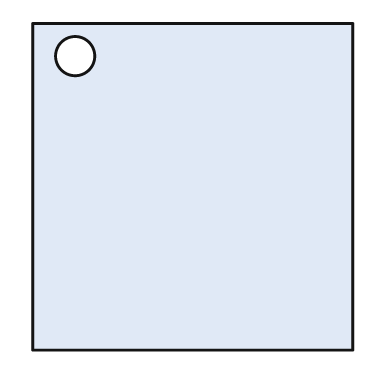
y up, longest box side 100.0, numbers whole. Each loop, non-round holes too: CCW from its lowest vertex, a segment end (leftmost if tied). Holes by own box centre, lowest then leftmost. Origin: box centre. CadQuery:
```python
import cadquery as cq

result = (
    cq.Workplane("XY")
    .moveTo(-49.0, -50.0)
    .lineTo(49.0, -50.0)
    .lineTo(49.0, 50.0)
    .lineTo(-49.0, 50.0)
    .close()
    .moveTo(-36.0, 40.0)
    .circle(6.0)
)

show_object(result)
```